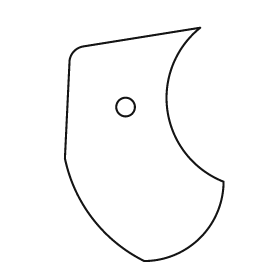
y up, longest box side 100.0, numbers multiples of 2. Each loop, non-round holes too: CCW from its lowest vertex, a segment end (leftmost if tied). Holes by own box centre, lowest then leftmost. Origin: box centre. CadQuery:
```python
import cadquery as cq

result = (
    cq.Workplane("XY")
    .moveTo(0.0, -50.0)
    .threePointArc((24.0, -40.0), (34.0, -16.0))
    .threePointArc((10.0, 14.0), (24.0, 50.0))
    .lineTo(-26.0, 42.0)
    .threePointArc((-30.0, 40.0), (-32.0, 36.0))
    .lineTo(-34.0, -6.0)
    .threePointArc((-22.0, -32.0), (0.0, -50.0))
    .close()
    .moveTo(-8.0, 16.0)
    .circle(4.0)
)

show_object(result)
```